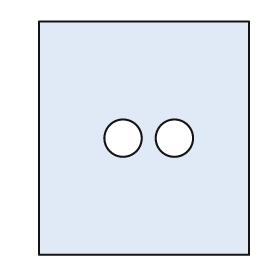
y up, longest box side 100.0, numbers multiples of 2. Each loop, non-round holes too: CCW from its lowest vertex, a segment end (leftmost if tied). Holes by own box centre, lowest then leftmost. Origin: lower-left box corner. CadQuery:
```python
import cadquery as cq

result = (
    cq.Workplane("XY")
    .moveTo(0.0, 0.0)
    .lineTo(90.0, 0.0)
    .lineTo(90.0, 100.0)
    .lineTo(0.0, 100.0)
    .close()
    .moveTo(36.0, 50.0)
    .circle(8.0)
    .moveTo(58.0, 50.0)
    .circle(8.0)
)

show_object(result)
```